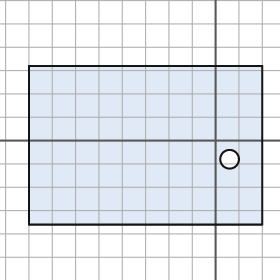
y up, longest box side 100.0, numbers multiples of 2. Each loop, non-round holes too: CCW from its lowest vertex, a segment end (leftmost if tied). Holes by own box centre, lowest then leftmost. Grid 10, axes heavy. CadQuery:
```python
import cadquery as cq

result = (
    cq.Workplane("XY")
    .moveTo(-80.0, -36.0)
    .lineTo(20.0, -36.0)
    .lineTo(20.0, 32.0)
    .lineTo(-80.0, 32.0)
    .close()
    .moveTo(6.0, -8.0)
    .circle(4.0)
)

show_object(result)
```